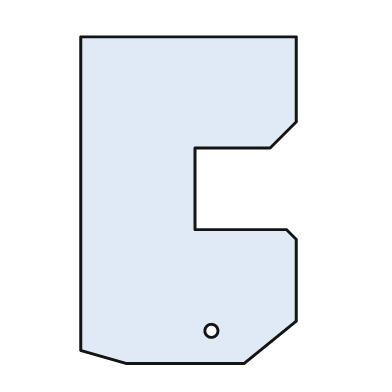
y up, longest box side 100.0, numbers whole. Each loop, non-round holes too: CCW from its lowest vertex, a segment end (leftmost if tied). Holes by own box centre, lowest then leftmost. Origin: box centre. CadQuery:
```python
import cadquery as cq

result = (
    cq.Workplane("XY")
    .moveTo(-19.0, -50.0)
    .lineTo(17.0, -50.0)
    .lineTo(33.0, -37.0)
    .lineTo(33.0, -12.0)
    .lineTo(30.0, -9.0)
    .lineTo(2.0, -9.0)
    .lineTo(2.0, 16.0)
    .lineTo(25.0, 16.0)
    .lineTo(33.0, 24.0)
    .lineTo(33.0, 50.0)
    .lineTo(-33.0, 50.0)
    .lineTo(-33.0, -46.0)
    .close()
    .moveTo(7.0, -40.0)
    .circle(2.0)
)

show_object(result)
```